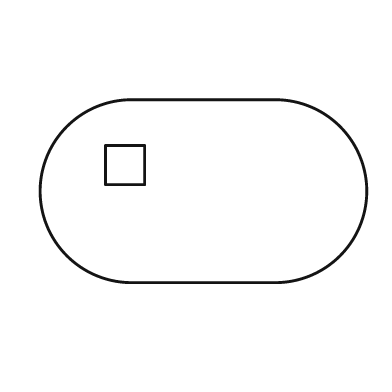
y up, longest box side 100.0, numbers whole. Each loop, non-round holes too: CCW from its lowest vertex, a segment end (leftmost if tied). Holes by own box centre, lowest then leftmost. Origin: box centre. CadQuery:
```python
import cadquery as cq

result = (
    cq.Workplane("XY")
    .moveTo(-22.0, -28.0)
    .lineTo(22.0, -28.0)
    .threePointArc((50.0, 0.0), (22.0, 28.0))
    .lineTo(-22.0, 28.0)
    .threePointArc((-50.0, 0.0), (-22.0, -28.0))
    .close()
    .moveTo(-30.0, 2.0)
    .lineTo(-18.0, 2.0)
    .lineTo(-18.0, 14.0)
    .lineTo(-30.0, 14.0)
    .close()
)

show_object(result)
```